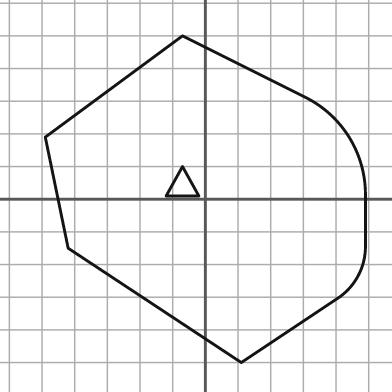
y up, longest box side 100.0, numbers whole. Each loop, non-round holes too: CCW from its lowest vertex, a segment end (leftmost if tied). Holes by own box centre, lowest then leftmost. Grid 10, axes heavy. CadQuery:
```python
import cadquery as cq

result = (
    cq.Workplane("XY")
    .moveTo(11.0, -50.0)
    .lineTo(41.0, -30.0)
    .threePointArc((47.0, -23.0), (49.0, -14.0))
    .lineTo(49.0, 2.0)
    .threePointArc((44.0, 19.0), (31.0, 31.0))
    .lineTo(-7.0, 50.0)
    .lineTo(-49.0, 19.0)
    .lineTo(-42.0, -15.0)
    .close()
    .moveTo(-12.0, 1.0)
    .lineTo(-2.0, 1.0)
    .lineTo(-7.0, 10.0)
    .close()
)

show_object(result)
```